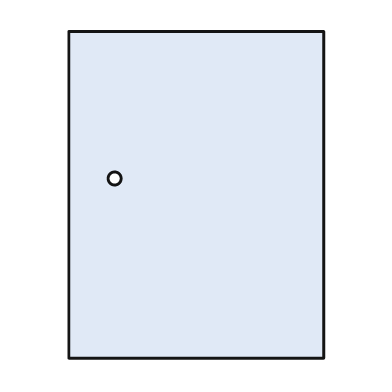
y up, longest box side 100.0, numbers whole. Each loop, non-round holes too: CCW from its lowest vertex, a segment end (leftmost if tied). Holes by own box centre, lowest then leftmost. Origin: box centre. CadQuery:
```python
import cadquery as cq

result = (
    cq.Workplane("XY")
    .moveTo(-39.0, -50.0)
    .lineTo(39.0, -50.0)
    .lineTo(39.0, 50.0)
    .lineTo(-39.0, 50.0)
    .close()
    .moveTo(-25.0, 5.0)
    .circle(2.0)
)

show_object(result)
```